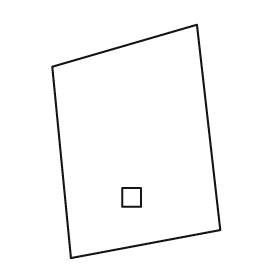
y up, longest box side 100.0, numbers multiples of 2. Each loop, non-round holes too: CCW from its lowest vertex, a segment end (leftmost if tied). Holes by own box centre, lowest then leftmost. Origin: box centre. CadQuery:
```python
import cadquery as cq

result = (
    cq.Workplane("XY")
    .moveTo(-28.0, -50.0)
    .lineTo(36.0, -38.0)
    .lineTo(26.0, 50.0)
    .lineTo(-36.0, 32.0)
    .close()
    .moveTo(-6.0, -28.0)
    .lineTo(2.0, -28.0)
    .lineTo(2.0, -20.0)
    .lineTo(-6.0, -20.0)
    .close()
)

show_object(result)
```